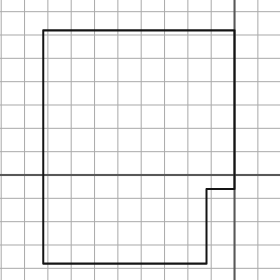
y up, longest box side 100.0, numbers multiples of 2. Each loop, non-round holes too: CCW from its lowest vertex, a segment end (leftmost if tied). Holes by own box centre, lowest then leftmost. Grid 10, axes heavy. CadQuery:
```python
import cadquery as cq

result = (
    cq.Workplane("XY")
    .moveTo(-82.0, -38.0)
    .lineTo(-12.0, -38.0)
    .lineTo(-12.0, -6.0)
    .lineTo(0.0, -6.0)
    .lineTo(0.0, 62.0)
    .lineTo(-82.0, 62.0)
    .close()
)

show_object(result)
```